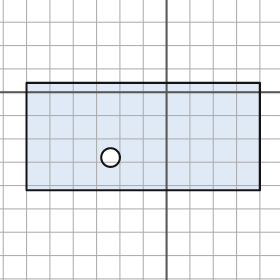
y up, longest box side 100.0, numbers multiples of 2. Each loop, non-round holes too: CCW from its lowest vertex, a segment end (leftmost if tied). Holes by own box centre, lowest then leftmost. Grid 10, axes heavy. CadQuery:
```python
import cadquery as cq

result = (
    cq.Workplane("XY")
    .moveTo(-60.0, -42.0)
    .lineTo(40.0, -42.0)
    .lineTo(40.0, 4.0)
    .lineTo(-60.0, 4.0)
    .close()
    .moveTo(-24.0, -28.0)
    .circle(4.0)
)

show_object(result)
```